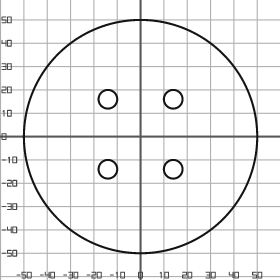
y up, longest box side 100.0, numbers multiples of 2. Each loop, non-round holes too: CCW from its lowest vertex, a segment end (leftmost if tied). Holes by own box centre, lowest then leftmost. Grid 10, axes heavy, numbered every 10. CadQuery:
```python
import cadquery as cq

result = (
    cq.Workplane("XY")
    .moveTo(0.0, 0.0)
    .circle(50.0)
    .moveTo(-14.0, -14.0)
    .circle(4.0)
    .moveTo(14.0, -14.0)
    .circle(4.0)
    .moveTo(-14.0, 16.0)
    .circle(4.0)
    .moveTo(14.0, 16.0)
    .circle(4.0)
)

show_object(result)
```